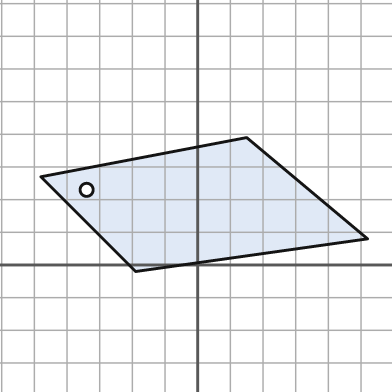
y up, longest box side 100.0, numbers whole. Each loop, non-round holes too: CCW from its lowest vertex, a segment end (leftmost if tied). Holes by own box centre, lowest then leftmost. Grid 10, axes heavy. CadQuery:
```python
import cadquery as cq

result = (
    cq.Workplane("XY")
    .moveTo(-19.0, -2.0)
    .lineTo(52.0, 8.0)
    .lineTo(15.0, 39.0)
    .lineTo(-48.0, 27.0)
    .close()
    .moveTo(-34.0, 23.0)
    .circle(2.0)
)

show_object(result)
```